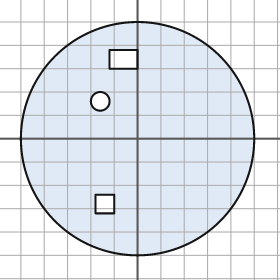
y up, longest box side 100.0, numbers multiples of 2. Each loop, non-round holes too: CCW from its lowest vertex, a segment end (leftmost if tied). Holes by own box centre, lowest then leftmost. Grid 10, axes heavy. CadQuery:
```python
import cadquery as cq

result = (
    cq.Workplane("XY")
    .moveTo(0.0, 0.0)
    .circle(50.0)
    .moveTo(-18.0, -32.0)
    .lineTo(-10.0, -32.0)
    .lineTo(-10.0, -24.0)
    .lineTo(-18.0, -24.0)
    .close()
    .moveTo(-16.0, 16.0)
    .circle(4.0)
    .moveTo(-12.0, 30.0)
    .lineTo(0.0, 30.0)
    .lineTo(0.0, 38.0)
    .lineTo(-12.0, 38.0)
    .close()
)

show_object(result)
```